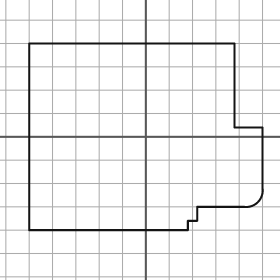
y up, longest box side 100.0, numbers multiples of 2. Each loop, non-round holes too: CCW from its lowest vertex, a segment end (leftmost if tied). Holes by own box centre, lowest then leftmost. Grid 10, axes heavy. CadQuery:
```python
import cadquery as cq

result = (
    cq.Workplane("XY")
    .moveTo(-50.0, -40.0)
    .lineTo(18.0, -40.0)
    .lineTo(18.0, -36.0)
    .lineTo(22.0, -36.0)
    .lineTo(22.0, -30.0)
    .lineTo(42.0, -30.0)
    .threePointArc((48.0, -28.0), (50.0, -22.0))
    .lineTo(50.0, 4.0)
    .lineTo(38.0, 4.0)
    .lineTo(38.0, 40.0)
    .lineTo(-50.0, 40.0)
    .close()
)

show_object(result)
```